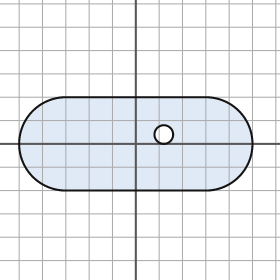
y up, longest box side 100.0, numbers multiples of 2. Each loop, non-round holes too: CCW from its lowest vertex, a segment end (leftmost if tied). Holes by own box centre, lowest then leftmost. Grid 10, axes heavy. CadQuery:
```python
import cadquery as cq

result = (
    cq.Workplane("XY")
    .moveTo(-30.0, -20.0)
    .lineTo(30.0, -20.0)
    .threePointArc((50.0, 0.0), (30.0, 20.0))
    .lineTo(-30.0, 20.0)
    .threePointArc((-50.0, 0.0), (-30.0, -20.0))
    .close()
    .moveTo(12.0, 4.0)
    .circle(4.0)
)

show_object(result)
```